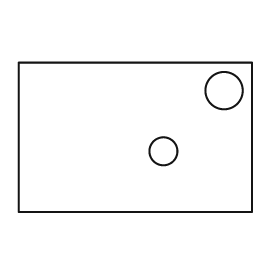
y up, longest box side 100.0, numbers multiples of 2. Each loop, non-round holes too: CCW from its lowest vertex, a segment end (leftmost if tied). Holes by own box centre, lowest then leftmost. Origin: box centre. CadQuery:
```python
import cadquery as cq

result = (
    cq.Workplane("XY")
    .moveTo(-50.0, -32.0)
    .lineTo(50.0, -32.0)
    .lineTo(50.0, 32.0)
    .lineTo(-50.0, 32.0)
    .close()
    .moveTo(12.0, -6.0)
    .circle(6.0)
    .moveTo(38.0, 20.0)
    .circle(8.0)
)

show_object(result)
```